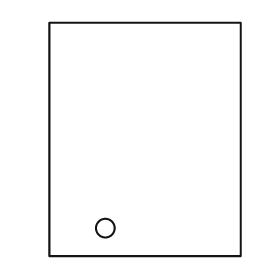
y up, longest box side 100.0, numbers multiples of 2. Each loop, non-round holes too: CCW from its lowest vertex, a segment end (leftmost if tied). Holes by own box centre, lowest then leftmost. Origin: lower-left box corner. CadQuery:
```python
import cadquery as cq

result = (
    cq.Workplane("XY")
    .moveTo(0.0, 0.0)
    .lineTo(82.0, 0.0)
    .lineTo(82.0, 100.0)
    .lineTo(0.0, 100.0)
    .close()
    .moveTo(24.0, 12.0)
    .circle(4.0)
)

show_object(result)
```